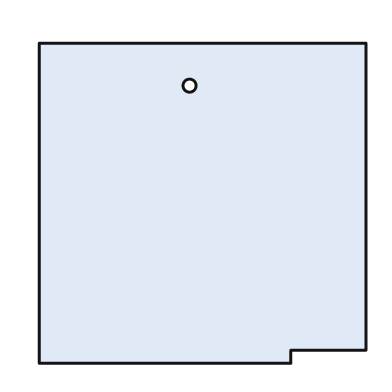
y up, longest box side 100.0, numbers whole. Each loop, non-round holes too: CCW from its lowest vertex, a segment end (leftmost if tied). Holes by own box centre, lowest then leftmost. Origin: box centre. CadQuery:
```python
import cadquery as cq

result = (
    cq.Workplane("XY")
    .moveTo(-50.0, -49.0)
    .lineTo(27.0, -49.0)
    .lineTo(27.0, -45.0)
    .lineTo(50.0, -45.0)
    .lineTo(50.0, 49.0)
    .lineTo(-50.0, 49.0)
    .close()
    .moveTo(-4.0, 36.0)
    .circle(2.0)
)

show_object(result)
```